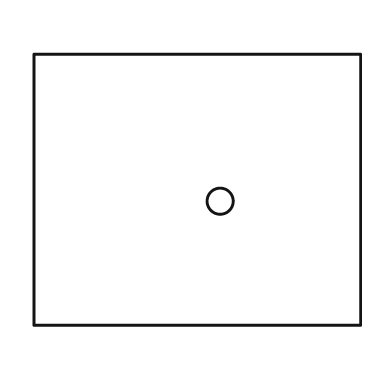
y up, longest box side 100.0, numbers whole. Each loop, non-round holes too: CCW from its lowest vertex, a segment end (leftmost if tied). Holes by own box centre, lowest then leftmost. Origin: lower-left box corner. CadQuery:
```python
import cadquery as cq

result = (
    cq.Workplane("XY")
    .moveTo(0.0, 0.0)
    .lineTo(100.0, 0.0)
    .lineTo(100.0, 83.0)
    .lineTo(0.0, 83.0)
    .close()
    .moveTo(57.0, 38.0)
    .circle(4.0)
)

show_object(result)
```